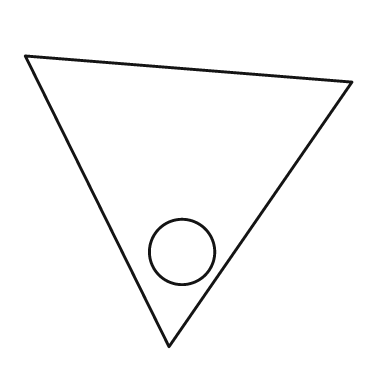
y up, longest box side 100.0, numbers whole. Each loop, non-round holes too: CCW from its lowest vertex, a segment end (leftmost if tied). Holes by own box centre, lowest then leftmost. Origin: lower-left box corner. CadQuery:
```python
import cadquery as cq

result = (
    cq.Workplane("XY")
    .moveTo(44.0, 0.0)
    .lineTo(100.0, 81.0)
    .lineTo(0.0, 89.0)
    .close()
    .moveTo(48.0, 29.0)
    .circle(10.0)
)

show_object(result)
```